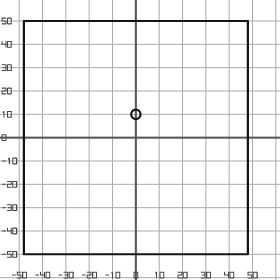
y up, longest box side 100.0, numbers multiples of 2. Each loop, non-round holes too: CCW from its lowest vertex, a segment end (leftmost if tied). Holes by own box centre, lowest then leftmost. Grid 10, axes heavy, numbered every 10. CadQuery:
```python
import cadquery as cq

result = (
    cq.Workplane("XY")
    .moveTo(-48.0, -50.0)
    .lineTo(48.0, -50.0)
    .lineTo(48.0, 50.0)
    .lineTo(-48.0, 50.0)
    .close()
    .moveTo(0.0, 10.0)
    .circle(2.0)
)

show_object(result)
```